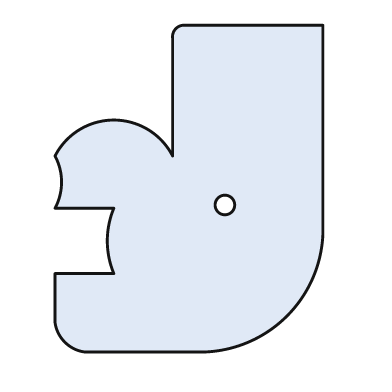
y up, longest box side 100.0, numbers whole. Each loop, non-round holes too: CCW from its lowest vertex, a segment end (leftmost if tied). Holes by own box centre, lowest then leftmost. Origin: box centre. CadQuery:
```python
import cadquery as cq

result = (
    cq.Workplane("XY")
    .moveTo(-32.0, -50.0)
    .lineTo(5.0, -50.0)
    .threePointArc((30.0, -39.0), (41.0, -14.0))
    .lineTo(41.0, 50.0)
    .lineTo(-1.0, 50.0)
    .threePointArc((-4.0, 49.0), (-5.0, 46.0))
    .lineTo(-5.0, 10.0)
    .threePointArc((-23.0, 21.0), (-41.0, 10.0))
    .threePointArc((-39.0, 2.0), (-41.0, -6.0))
    .lineTo(-23.0, -6.0)
    .threePointArc((-25.0, -16.0), (-23.0, -26.0))
    .lineTo(-41.0, -26.0)
    .lineTo(-41.0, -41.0)
    .threePointArc((-38.0, -47.0), (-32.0, -50.0))
    .close()
    .moveTo(11.0, -5.0)
    .circle(3.0)
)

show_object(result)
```